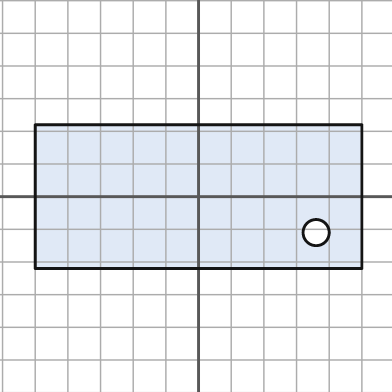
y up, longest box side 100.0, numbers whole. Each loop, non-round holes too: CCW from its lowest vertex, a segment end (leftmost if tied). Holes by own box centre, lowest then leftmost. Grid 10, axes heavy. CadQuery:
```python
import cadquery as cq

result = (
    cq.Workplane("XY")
    .moveTo(-50.0, -22.0)
    .lineTo(50.0, -22.0)
    .lineTo(50.0, 22.0)
    .lineTo(-50.0, 22.0)
    .close()
    .moveTo(36.0, -11.0)
    .circle(4.0)
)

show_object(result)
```